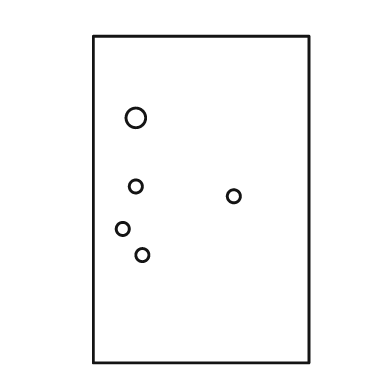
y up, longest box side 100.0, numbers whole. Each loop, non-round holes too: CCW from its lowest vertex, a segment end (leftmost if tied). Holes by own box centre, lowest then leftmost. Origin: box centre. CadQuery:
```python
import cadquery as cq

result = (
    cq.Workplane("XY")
    .moveTo(-33.0, -50.0)
    .lineTo(33.0, -50.0)
    .lineTo(33.0, 50.0)
    .lineTo(-33.0, 50.0)
    .close()
    .moveTo(-18.0, -17.0)
    .circle(2.0)
    .moveTo(-24.0, -9.0)
    .circle(2.0)
    .moveTo(10.0, 1.0)
    .circle(2.0)
    .moveTo(-20.0, 4.0)
    .circle(2.0)
    .moveTo(-20.0, 25.0)
    .circle(3.0)
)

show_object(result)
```